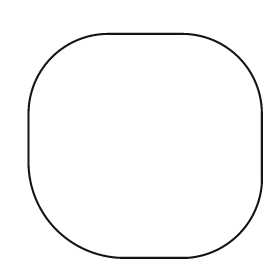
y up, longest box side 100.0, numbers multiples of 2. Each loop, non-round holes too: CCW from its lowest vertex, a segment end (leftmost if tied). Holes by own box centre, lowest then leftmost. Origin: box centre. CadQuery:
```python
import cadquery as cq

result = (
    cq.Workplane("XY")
    .moveTo(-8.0, -48.0)
    .lineTo(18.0, -48.0)
    .threePointArc((40.0, -38.0), (50.0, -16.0))
    .lineTo(50.0, 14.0)
    .threePointArc((40.0, 38.0), (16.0, 48.0))
    .lineTo(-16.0, 48.0)
    .threePointArc((-40.0, 38.0), (-50.0, 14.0))
    .lineTo(-50.0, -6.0)
    .threePointArc((-38.0, -36.0), (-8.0, -48.0))
    .close()
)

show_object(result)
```